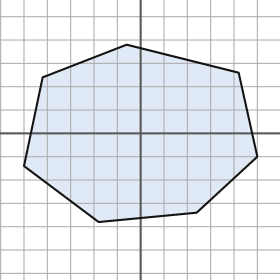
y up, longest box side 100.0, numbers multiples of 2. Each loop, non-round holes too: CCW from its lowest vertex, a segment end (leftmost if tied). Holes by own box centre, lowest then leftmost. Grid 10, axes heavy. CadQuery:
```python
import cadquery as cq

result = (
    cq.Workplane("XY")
    .moveTo(-18.0, -38.0)
    .lineTo(24.0, -34.0)
    .lineTo(50.0, -10.0)
    .lineTo(42.0, 26.0)
    .lineTo(-6.0, 38.0)
    .lineTo(-42.0, 24.0)
    .lineTo(-50.0, -14.0)
    .close()
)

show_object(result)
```